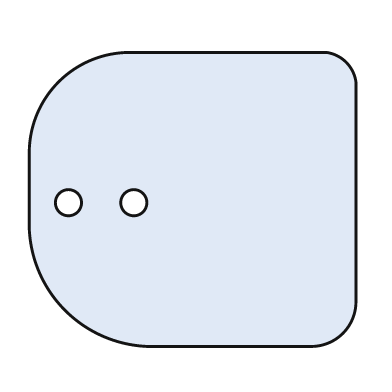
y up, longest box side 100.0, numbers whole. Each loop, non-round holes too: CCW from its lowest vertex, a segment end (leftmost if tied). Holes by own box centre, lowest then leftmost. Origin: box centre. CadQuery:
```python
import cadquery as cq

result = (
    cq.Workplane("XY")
    .moveTo(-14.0, -45.0)
    .lineTo(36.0, -45.0)
    .threePointArc((46.0, -41.0), (50.0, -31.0))
    .lineTo(50.0, 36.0)
    .threePointArc((47.0, 42.0), (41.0, 45.0))
    .lineTo(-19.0, 45.0)
    .threePointArc((-41.0, 36.0), (-50.0, 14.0))
    .lineTo(-50.0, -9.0)
    .threePointArc((-39.0, -34.0), (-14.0, -45.0))
    .close()
    .moveTo(-38.0, -1.0)
    .circle(4.0)
    .moveTo(-18.0, -1.0)
    .circle(4.0)
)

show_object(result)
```